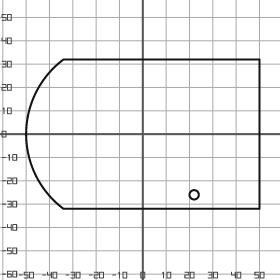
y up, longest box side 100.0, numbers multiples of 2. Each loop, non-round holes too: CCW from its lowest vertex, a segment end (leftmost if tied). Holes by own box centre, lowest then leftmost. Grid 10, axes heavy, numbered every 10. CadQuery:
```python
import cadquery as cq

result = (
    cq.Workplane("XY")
    .moveTo(-34.0, -32.0)
    .lineTo(50.0, -32.0)
    .lineTo(50.0, 32.0)
    .lineTo(-34.0, 32.0)
    .threePointArc((-50.0, 0.0), (-34.0, -32.0))
    .close()
    .moveTo(22.0, -26.0)
    .circle(2.0)
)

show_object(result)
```